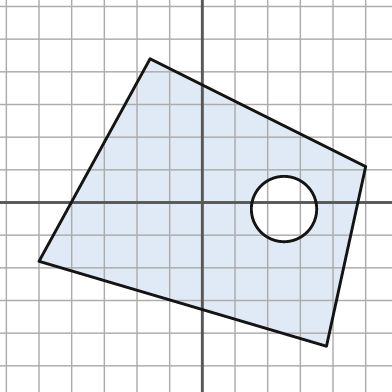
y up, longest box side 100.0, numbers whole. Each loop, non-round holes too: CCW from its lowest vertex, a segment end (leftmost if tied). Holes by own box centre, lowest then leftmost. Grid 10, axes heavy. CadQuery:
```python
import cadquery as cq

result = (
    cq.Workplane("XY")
    .moveTo(38.0, -44.0)
    .lineTo(50.0, 11.0)
    .lineTo(-16.0, 44.0)
    .lineTo(-50.0, -18.0)
    .close()
    .moveTo(25.0, -2.0)
    .circle(10.0)
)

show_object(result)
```